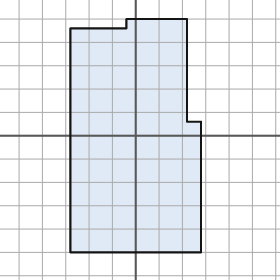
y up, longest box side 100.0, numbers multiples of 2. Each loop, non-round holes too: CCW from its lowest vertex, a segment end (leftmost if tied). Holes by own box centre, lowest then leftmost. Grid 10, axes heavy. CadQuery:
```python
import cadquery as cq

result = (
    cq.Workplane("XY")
    .moveTo(-28.0, -50.0)
    .lineTo(28.0, -50.0)
    .lineTo(28.0, 6.0)
    .lineTo(22.0, 6.0)
    .lineTo(22.0, 50.0)
    .lineTo(-4.0, 50.0)
    .lineTo(-4.0, 46.0)
    .lineTo(-28.0, 46.0)
    .close()
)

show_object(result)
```